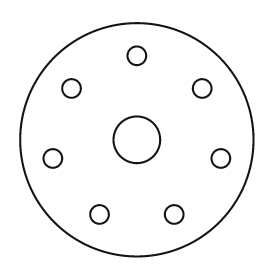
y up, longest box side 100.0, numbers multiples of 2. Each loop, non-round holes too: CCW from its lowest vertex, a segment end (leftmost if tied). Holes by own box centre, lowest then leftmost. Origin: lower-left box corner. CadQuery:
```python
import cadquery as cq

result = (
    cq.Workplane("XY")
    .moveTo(50.0, 50.0)
    .circle(50.0)
    .moveTo(34.0, 18.0)
    .circle(4.0)
    .moveTo(66.0, 18.0)
    .circle(4.0)
    .moveTo(14.0, 42.0)
    .circle(4.0)
    .moveTo(86.0, 42.0)
    .circle(4.0)
    .moveTo(50.0, 50.0)
    .circle(10.0)
    .moveTo(22.0, 72.0)
    .circle(4.0)
    .moveTo(78.0, 72.0)
    .circle(4.0)
    .moveTo(50.0, 86.0)
    .circle(4.0)
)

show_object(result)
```